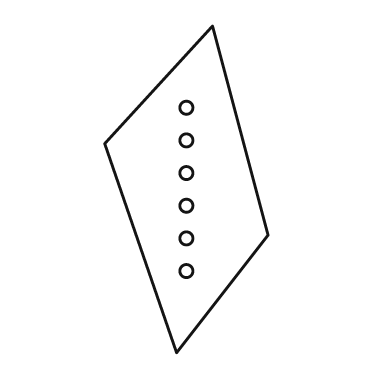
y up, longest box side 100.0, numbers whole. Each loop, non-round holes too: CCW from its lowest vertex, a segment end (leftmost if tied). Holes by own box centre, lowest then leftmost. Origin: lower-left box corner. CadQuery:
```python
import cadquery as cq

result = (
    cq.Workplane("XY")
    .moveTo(22.0, 0.0)
    .lineTo(50.0, 36.0)
    .lineTo(33.0, 100.0)
    .lineTo(0.0, 64.0)
    .close()
    .moveTo(25.0, 25.0)
    .circle(2.0)
    .moveTo(25.0, 35.0)
    .circle(2.0)
    .moveTo(25.0, 45.0)
    .circle(2.0)
    .moveTo(25.0, 55.0)
    .circle(2.0)
    .moveTo(25.0, 65.0)
    .circle(2.0)
    .moveTo(25.0, 75.0)
    .circle(2.0)
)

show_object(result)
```